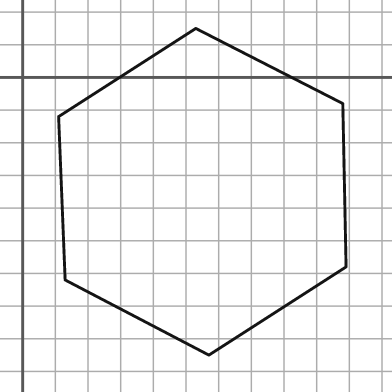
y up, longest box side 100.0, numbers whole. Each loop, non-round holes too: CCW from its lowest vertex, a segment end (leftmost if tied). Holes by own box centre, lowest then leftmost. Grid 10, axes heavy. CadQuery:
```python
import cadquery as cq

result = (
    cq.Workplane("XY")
    .moveTo(57.0, -85.0)
    .lineTo(99.0, -58.0)
    .lineTo(98.0, -8.0)
    .lineTo(53.0, 15.0)
    .lineTo(11.0, -12.0)
    .lineTo(13.0, -62.0)
    .close()
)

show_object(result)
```